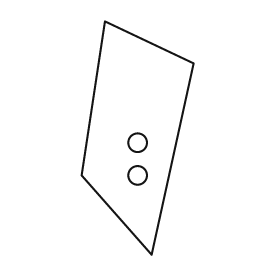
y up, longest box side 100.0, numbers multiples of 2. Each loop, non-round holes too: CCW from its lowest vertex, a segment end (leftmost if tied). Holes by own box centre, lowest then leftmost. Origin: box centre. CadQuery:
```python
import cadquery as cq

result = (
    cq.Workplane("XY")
    .moveTo(6.0, -50.0)
    .lineTo(24.0, 32.0)
    .lineTo(-14.0, 50.0)
    .lineTo(-24.0, -16.0)
    .close()
    .moveTo(0.0, -16.0)
    .circle(4.0)
    .moveTo(0.0, -2.0)
    .circle(4.0)
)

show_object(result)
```